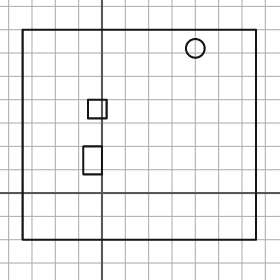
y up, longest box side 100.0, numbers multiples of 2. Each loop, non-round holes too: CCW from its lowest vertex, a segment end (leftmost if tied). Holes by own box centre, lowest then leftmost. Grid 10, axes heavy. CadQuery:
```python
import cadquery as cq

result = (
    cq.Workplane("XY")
    .moveTo(-34.0, -20.0)
    .lineTo(66.0, -20.0)
    .lineTo(66.0, 70.0)
    .lineTo(-34.0, 70.0)
    .close()
    .moveTo(-8.0, 8.0)
    .lineTo(0.0, 8.0)
    .lineTo(0.0, 20.0)
    .lineTo(-8.0, 20.0)
    .close()
    .moveTo(-6.0, 32.0)
    .lineTo(2.0, 32.0)
    .lineTo(2.0, 40.0)
    .lineTo(-6.0, 40.0)
    .close()
    .moveTo(40.0, 62.0)
    .circle(4.0)
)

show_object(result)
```